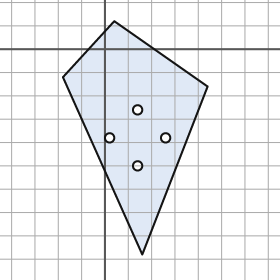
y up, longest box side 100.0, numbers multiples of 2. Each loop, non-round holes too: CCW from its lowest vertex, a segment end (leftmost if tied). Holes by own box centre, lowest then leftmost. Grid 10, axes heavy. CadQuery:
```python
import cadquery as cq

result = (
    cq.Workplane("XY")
    .moveTo(16.0, -88.0)
    .lineTo(44.0, -16.0)
    .lineTo(4.0, 12.0)
    .lineTo(-18.0, -12.0)
    .close()
    .moveTo(14.0, -50.0)
    .circle(2.0)
    .moveTo(2.0, -38.0)
    .circle(2.0)
    .moveTo(26.0, -38.0)
    .circle(2.0)
    .moveTo(14.0, -26.0)
    .circle(2.0)
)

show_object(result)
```